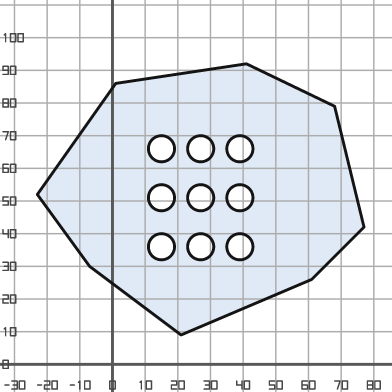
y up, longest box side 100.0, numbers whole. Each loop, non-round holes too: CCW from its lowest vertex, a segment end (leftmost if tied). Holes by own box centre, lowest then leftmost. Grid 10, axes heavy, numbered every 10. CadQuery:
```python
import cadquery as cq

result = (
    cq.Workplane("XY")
    .moveTo(21.0, 9.0)
    .lineTo(61.0, 26.0)
    .lineTo(77.0, 42.0)
    .lineTo(68.0, 79.0)
    .lineTo(41.0, 92.0)
    .lineTo(1.0, 86.0)
    .lineTo(-23.0, 52.0)
    .lineTo(-7.0, 30.0)
    .close()
    .moveTo(15.0, 36.0)
    .circle(4.0)
    .moveTo(27.0, 36.0)
    .circle(4.0)
    .moveTo(39.0, 36.0)
    .circle(4.0)
    .moveTo(15.0, 51.0)
    .circle(4.0)
    .moveTo(27.0, 51.0)
    .circle(4.0)
    .moveTo(39.0, 51.0)
    .circle(4.0)
    .moveTo(15.0, 66.0)
    .circle(4.0)
    .moveTo(27.0, 66.0)
    .circle(4.0)
    .moveTo(39.0, 66.0)
    .circle(4.0)
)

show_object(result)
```